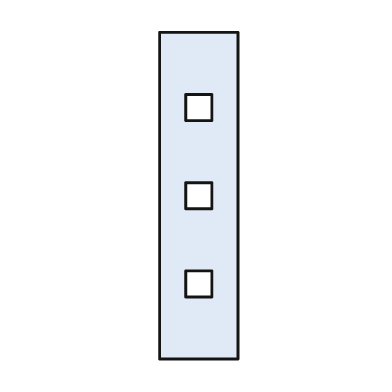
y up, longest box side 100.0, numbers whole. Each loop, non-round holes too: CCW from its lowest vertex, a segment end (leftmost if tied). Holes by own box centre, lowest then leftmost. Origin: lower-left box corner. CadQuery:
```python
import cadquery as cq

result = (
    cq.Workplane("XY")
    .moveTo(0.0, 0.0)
    .lineTo(24.0, 0.0)
    .lineTo(24.0, 100.0)
    .lineTo(0.0, 100.0)
    .close()
    .moveTo(8.0, 19.0)
    .lineTo(16.0, 19.0)
    .lineTo(16.0, 27.0)
    .lineTo(8.0, 27.0)
    .close()
    .moveTo(8.0, 46.0)
    .lineTo(16.0, 46.0)
    .lineTo(16.0, 54.0)
    .lineTo(8.0, 54.0)
    .close()
    .moveTo(8.0, 73.0)
    .lineTo(16.0, 73.0)
    .lineTo(16.0, 81.0)
    .lineTo(8.0, 81.0)
    .close()
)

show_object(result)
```